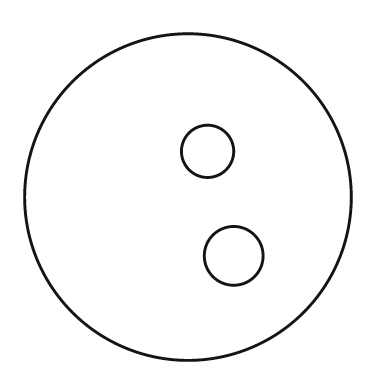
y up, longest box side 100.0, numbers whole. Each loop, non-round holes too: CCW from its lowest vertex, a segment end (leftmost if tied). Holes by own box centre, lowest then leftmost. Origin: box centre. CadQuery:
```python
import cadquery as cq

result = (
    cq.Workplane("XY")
    .moveTo(0.0, 0.0)
    .circle(50.0)
    .moveTo(14.0, -18.0)
    .circle(9.0)
    .moveTo(6.0, 14.0)
    .circle(8.0)
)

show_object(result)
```